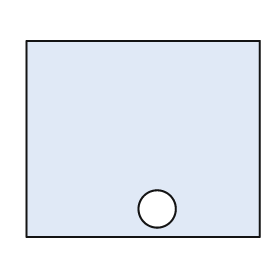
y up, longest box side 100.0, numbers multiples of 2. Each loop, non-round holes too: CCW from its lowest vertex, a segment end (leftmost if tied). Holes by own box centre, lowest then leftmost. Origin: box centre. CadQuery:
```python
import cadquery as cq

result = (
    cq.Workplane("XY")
    .moveTo(-50.0, -42.0)
    .lineTo(50.0, -42.0)
    .lineTo(50.0, 42.0)
    .lineTo(-50.0, 42.0)
    .close()
    .moveTo(6.0, -30.0)
    .circle(8.0)
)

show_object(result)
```